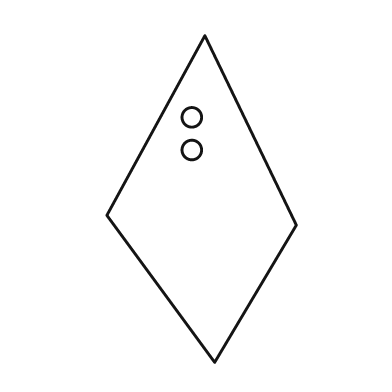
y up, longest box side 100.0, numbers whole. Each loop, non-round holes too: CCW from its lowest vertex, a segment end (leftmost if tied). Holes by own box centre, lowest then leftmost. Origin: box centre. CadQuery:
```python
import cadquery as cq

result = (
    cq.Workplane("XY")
    .moveTo(4.0, -50.0)
    .lineTo(29.0, -8.0)
    .lineTo(1.0, 50.0)
    .lineTo(-29.0, -5.0)
    .close()
    .moveTo(-3.0, 15.0)
    .circle(3.0)
    .moveTo(-3.0, 25.0)
    .circle(3.0)
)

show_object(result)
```